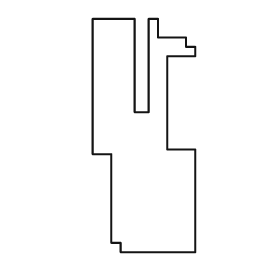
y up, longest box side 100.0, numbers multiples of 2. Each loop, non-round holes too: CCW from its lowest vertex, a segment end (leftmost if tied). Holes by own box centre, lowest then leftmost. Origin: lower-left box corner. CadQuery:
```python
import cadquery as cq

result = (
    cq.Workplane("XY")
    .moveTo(12.0, 0.0)
    .lineTo(44.0, 0.0)
    .lineTo(44.0, 44.0)
    .lineTo(32.0, 44.0)
    .lineTo(32.0, 84.0)
    .lineTo(44.0, 84.0)
    .lineTo(44.0, 88.0)
    .lineTo(40.0, 88.0)
    .lineTo(40.0, 92.0)
    .lineTo(28.0, 92.0)
    .lineTo(28.0, 100.0)
    .lineTo(24.0, 100.0)
    .lineTo(24.0, 60.0)
    .lineTo(18.0, 60.0)
    .lineTo(18.0, 100.0)
    .lineTo(0.0, 100.0)
    .lineTo(0.0, 42.0)
    .lineTo(8.0, 42.0)
    .lineTo(8.0, 4.0)
    .lineTo(12.0, 4.0)
    .close()
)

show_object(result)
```